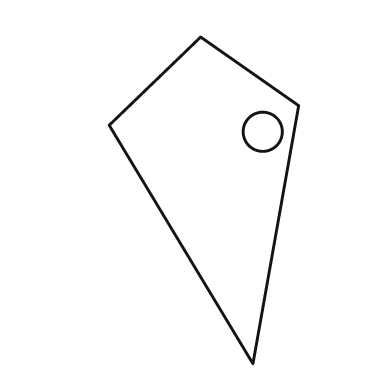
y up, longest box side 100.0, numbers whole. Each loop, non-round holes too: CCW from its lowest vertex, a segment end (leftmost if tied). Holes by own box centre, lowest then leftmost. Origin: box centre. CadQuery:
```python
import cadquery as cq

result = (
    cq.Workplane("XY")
    .moveTo(15.0, -50.0)
    .lineTo(29.0, 29.0)
    .lineTo(-1.0, 50.0)
    .lineTo(-29.0, 23.0)
    .close()
    .moveTo(18.0, 21.0)
    .circle(6.0)
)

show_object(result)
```